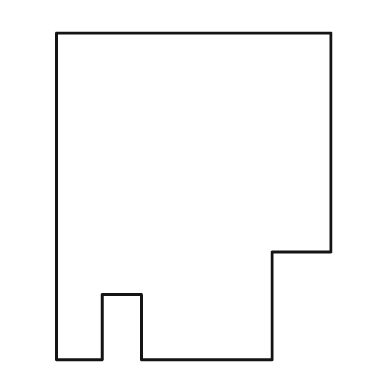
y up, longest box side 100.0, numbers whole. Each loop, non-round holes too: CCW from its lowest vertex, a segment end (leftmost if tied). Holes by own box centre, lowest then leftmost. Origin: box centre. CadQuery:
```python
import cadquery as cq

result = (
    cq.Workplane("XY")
    .moveTo(-42.0, -50.0)
    .lineTo(-28.0, -50.0)
    .lineTo(-28.0, -30.0)
    .lineTo(-16.0, -30.0)
    .lineTo(-16.0, -50.0)
    .lineTo(24.0, -50.0)
    .lineTo(24.0, -17.0)
    .lineTo(42.0, -17.0)
    .lineTo(42.0, 50.0)
    .lineTo(-42.0, 50.0)
    .close()
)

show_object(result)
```